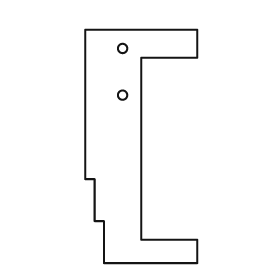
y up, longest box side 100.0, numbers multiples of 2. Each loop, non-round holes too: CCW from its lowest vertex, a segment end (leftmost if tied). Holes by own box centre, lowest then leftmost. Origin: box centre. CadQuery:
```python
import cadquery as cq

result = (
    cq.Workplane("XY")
    .moveTo(-16.0, -50.0)
    .lineTo(24.0, -50.0)
    .lineTo(24.0, -40.0)
    .lineTo(0.0, -40.0)
    .lineTo(0.0, 38.0)
    .lineTo(24.0, 38.0)
    .lineTo(24.0, 50.0)
    .lineTo(-24.0, 50.0)
    .lineTo(-24.0, -14.0)
    .lineTo(-20.0, -14.0)
    .lineTo(-20.0, -32.0)
    .lineTo(-16.0, -32.0)
    .close()
    .moveTo(-8.0, 22.0)
    .circle(2.0)
    .moveTo(-8.0, 42.0)
    .circle(2.0)
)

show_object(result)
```